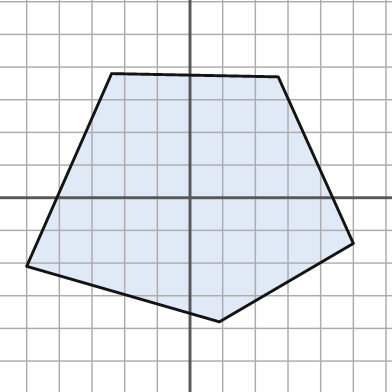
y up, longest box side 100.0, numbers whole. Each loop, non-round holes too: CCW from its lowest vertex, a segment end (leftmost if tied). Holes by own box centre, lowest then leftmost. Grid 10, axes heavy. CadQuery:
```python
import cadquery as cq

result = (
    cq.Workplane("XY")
    .moveTo(9.0, -38.0)
    .lineTo(50.0, -14.0)
    .lineTo(27.0, 37.0)
    .lineTo(-24.0, 38.0)
    .lineTo(-50.0, -21.0)
    .close()
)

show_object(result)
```